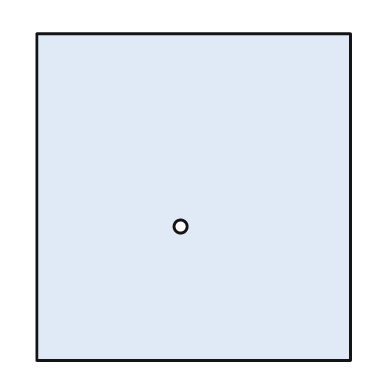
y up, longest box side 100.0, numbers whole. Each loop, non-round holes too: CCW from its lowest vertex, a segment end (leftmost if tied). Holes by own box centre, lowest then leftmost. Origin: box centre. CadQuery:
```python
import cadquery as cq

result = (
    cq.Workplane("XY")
    .moveTo(-48.0, -50.0)
    .lineTo(48.0, -50.0)
    .lineTo(48.0, 50.0)
    .lineTo(-48.0, 50.0)
    .close()
    .moveTo(-4.0, -9.0)
    .circle(2.0)
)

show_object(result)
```